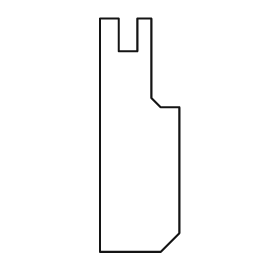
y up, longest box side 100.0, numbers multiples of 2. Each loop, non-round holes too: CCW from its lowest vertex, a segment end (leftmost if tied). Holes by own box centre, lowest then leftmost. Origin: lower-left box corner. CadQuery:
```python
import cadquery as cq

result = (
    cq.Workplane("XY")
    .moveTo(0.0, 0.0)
    .lineTo(26.0, 0.0)
    .lineTo(34.0, 8.0)
    .lineTo(34.0, 62.0)
    .lineTo(26.0, 62.0)
    .lineTo(22.0, 66.0)
    .lineTo(22.0, 100.0)
    .lineTo(16.0, 100.0)
    .lineTo(16.0, 86.0)
    .lineTo(8.0, 86.0)
    .lineTo(8.0, 100.0)
    .lineTo(0.0, 100.0)
    .close()
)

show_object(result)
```